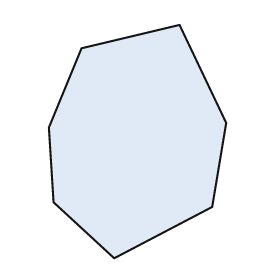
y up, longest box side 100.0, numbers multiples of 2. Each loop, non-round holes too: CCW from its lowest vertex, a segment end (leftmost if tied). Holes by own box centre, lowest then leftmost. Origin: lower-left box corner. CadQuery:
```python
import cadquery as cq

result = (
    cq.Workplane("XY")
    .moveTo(28.0, 0.0)
    .lineTo(70.0, 22.0)
    .lineTo(76.0, 58.0)
    .lineTo(56.0, 100.0)
    .lineTo(14.0, 90.0)
    .lineTo(0.0, 56.0)
    .lineTo(2.0, 24.0)
    .close()
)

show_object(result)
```